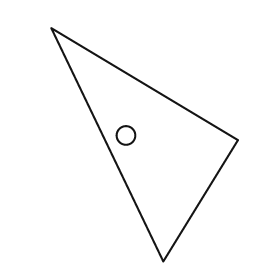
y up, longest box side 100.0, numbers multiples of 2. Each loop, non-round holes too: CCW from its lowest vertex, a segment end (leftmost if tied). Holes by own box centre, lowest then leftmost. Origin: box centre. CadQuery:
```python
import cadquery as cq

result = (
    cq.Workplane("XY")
    .moveTo(8.0, -50.0)
    .lineTo(40.0, 2.0)
    .lineTo(-40.0, 50.0)
    .close()
    .moveTo(-8.0, 4.0)
    .circle(4.0)
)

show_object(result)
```